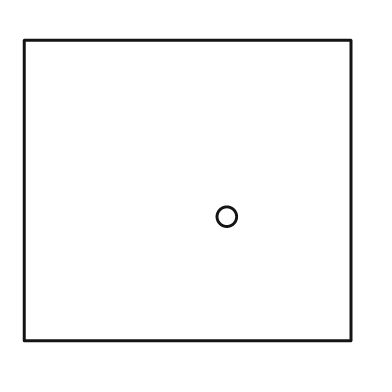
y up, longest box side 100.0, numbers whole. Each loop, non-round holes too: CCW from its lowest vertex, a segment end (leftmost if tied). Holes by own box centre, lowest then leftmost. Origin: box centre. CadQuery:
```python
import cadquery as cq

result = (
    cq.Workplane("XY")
    .moveTo(-50.0, -46.0)
    .lineTo(50.0, -46.0)
    .lineTo(50.0, 46.0)
    .lineTo(-50.0, 46.0)
    .close()
    .moveTo(12.0, -8.0)
    .circle(3.0)
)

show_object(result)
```